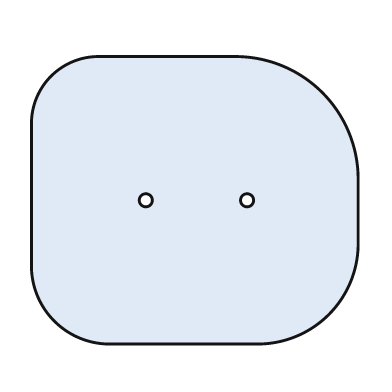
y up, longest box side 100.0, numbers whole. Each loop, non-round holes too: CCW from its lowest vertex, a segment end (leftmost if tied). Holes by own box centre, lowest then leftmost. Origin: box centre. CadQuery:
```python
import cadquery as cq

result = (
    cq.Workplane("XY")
    .moveTo(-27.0, -44.0)
    .lineTo(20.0, -44.0)
    .threePointArc((41.0, -35.0), (50.0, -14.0))
    .lineTo(50.0, 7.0)
    .threePointArc((39.0, 33.0), (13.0, 44.0))
    .lineTo(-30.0, 44.0)
    .threePointArc((-44.0, 38.0), (-50.0, 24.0))
    .lineTo(-50.0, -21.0)
    .threePointArc((-43.0, -37.0), (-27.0, -44.0))
    .close()
    .moveTo(-15.0, 0.0)
    .circle(2.0)
    .moveTo(16.0, 0.0)
    .circle(2.0)
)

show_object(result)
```